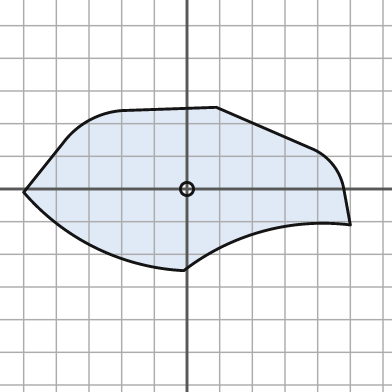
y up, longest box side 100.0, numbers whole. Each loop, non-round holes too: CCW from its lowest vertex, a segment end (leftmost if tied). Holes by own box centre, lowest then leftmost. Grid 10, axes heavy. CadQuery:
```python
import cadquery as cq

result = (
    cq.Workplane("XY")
    .moveTo(-1.0, -25.0)
    .threePointArc((23.0, -13.0), (50.0, -11.0))
    .lineTo(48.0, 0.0)
    .threePointArc((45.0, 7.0), (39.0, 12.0))
    .lineTo(9.0, 25.0)
    .lineTo(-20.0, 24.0)
    .threePointArc((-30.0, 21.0), (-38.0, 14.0))
    .lineTo(-50.0, -1.0)
    .threePointArc((-28.0, -18.0), (-1.0, -25.0))
    .close()
    .moveTo(0.0, 0.0)
    .circle(2.0)
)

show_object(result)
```